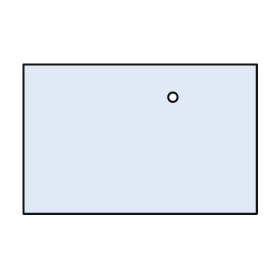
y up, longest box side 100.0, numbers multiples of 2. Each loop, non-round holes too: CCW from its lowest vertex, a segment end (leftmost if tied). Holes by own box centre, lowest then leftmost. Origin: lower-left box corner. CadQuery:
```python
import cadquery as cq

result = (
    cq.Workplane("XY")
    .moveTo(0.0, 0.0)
    .lineTo(100.0, 0.0)
    .lineTo(100.0, 64.0)
    .lineTo(0.0, 64.0)
    .close()
    .moveTo(64.0, 50.0)
    .circle(2.0)
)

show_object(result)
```